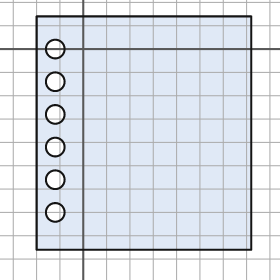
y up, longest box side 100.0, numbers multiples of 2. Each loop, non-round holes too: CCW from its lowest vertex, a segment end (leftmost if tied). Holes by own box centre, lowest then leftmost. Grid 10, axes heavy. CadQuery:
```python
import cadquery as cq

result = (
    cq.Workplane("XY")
    .moveTo(-20.0, -86.0)
    .lineTo(72.0, -86.0)
    .lineTo(72.0, 14.0)
    .lineTo(-20.0, 14.0)
    .close()
    .moveTo(-12.0, -70.0)
    .circle(4.0)
    .moveTo(-12.0, -56.0)
    .circle(4.0)
    .moveTo(-12.0, -42.0)
    .circle(4.0)
    .moveTo(-12.0, -28.0)
    .circle(4.0)
    .moveTo(-12.0, -14.0)
    .circle(4.0)
    .moveTo(-12.0, 0.0)
    .circle(4.0)
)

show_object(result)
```